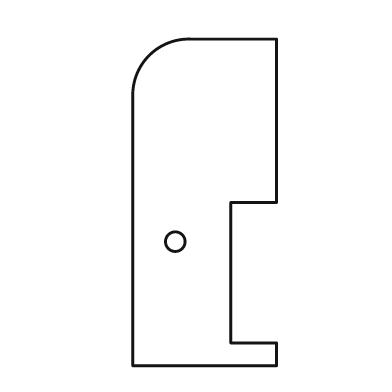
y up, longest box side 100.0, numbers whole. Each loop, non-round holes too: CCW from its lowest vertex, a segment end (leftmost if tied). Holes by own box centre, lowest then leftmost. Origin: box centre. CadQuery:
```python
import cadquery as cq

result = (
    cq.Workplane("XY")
    .moveTo(-22.0, -50.0)
    .lineTo(22.0, -50.0)
    .lineTo(22.0, -43.0)
    .lineTo(8.0, -43.0)
    .lineTo(8.0, 0.0)
    .lineTo(22.0, 0.0)
    .lineTo(22.0, 50.0)
    .lineTo(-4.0, 50.0)
    .threePointArc((-17.0, 45.0), (-22.0, 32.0))
    .close()
    .moveTo(-9.0, -12.0)
    .circle(3.0)
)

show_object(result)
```